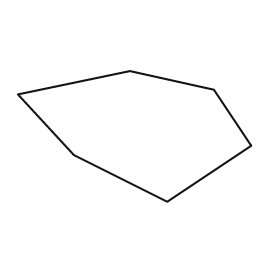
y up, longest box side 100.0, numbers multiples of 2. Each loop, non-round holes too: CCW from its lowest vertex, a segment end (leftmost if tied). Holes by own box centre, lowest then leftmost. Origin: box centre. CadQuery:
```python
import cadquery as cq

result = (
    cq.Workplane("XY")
    .moveTo(14.0, -28.0)
    .lineTo(50.0, -4.0)
    .lineTo(34.0, 20.0)
    .lineTo(-2.0, 28.0)
    .lineTo(-50.0, 18.0)
    .lineTo(-26.0, -8.0)
    .close()
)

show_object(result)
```